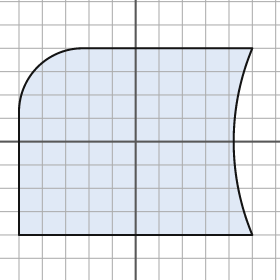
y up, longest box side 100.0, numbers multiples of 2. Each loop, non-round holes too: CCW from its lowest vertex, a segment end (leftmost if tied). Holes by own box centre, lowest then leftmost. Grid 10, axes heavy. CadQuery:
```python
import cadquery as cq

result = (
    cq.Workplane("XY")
    .moveTo(-50.0, -40.0)
    .lineTo(50.0, -40.0)
    .threePointArc((42.0, 0.0), (50.0, 40.0))
    .lineTo(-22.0, 40.0)
    .threePointArc((-42.0, 32.0), (-50.0, 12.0))
    .close()
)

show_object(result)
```